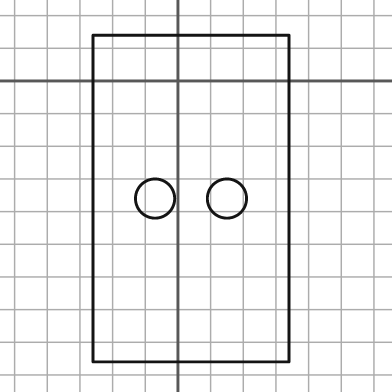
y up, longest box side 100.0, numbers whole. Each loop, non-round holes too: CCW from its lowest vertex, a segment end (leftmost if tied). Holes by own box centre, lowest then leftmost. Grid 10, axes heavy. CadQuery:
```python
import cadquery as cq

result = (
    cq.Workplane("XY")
    .moveTo(-26.0, -86.0)
    .lineTo(34.0, -86.0)
    .lineTo(34.0, 14.0)
    .lineTo(-26.0, 14.0)
    .close()
    .moveTo(-7.0, -36.0)
    .circle(6.0)
    .moveTo(15.0, -36.0)
    .circle(6.0)
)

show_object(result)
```